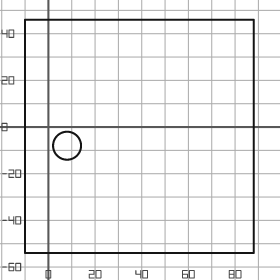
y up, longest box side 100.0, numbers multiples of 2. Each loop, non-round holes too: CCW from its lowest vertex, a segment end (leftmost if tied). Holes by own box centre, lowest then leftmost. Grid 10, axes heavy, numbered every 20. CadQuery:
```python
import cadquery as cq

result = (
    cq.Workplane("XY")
    .moveTo(-10.0, -54.0)
    .lineTo(88.0, -54.0)
    .lineTo(88.0, 46.0)
    .lineTo(-10.0, 46.0)
    .close()
    .moveTo(8.0, -8.0)
    .circle(6.0)
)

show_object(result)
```